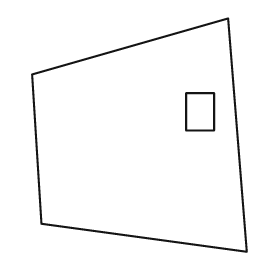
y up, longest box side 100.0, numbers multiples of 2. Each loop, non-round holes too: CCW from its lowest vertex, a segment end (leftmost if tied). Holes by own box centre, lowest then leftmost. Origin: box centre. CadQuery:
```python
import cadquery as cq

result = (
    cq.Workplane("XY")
    .moveTo(46.0, -50.0)
    .lineTo(38.0, 50.0)
    .lineTo(-46.0, 26.0)
    .lineTo(-42.0, -38.0)
    .close()
    .moveTo(20.0, 2.0)
    .lineTo(32.0, 2.0)
    .lineTo(32.0, 18.0)
    .lineTo(20.0, 18.0)
    .close()
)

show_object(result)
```